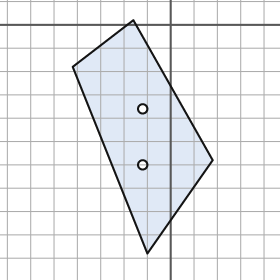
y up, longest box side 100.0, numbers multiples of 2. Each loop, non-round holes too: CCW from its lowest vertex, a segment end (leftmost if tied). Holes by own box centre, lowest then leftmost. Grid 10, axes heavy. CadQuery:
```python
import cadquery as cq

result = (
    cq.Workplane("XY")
    .moveTo(-10.0, -98.0)
    .lineTo(18.0, -58.0)
    .lineTo(-16.0, 2.0)
    .lineTo(-42.0, -18.0)
    .close()
    .moveTo(-12.0, -60.0)
    .circle(2.0)
    .moveTo(-12.0, -36.0)
    .circle(2.0)
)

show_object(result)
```